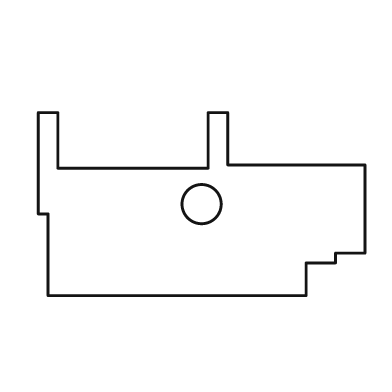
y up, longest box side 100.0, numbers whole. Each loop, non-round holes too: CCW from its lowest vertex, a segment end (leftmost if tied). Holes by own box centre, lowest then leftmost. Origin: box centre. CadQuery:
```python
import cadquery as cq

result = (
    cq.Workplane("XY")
    .moveTo(-47.0, -28.0)
    .lineTo(32.0, -28.0)
    .lineTo(32.0, -18.0)
    .lineTo(41.0, -18.0)
    .lineTo(41.0, -15.0)
    .lineTo(50.0, -15.0)
    .lineTo(50.0, 12.0)
    .lineTo(8.0, 12.0)
    .lineTo(8.0, 28.0)
    .lineTo(2.0, 28.0)
    .lineTo(2.0, 11.0)
    .lineTo(-44.0, 11.0)
    .lineTo(-44.0, 28.0)
    .lineTo(-50.0, 28.0)
    .lineTo(-50.0, -3.0)
    .lineTo(-47.0, -3.0)
    .close()
    .moveTo(0.0, 0.0)
    .circle(6.0)
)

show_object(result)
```